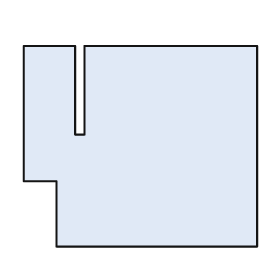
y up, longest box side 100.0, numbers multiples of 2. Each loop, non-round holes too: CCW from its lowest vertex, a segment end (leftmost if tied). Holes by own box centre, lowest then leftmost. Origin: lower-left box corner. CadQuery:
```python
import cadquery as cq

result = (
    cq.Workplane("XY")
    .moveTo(14.0, 0.0)
    .lineTo(100.0, 0.0)
    .lineTo(100.0, 86.0)
    .lineTo(26.0, 86.0)
    .lineTo(26.0, 48.0)
    .lineTo(22.0, 48.0)
    .lineTo(22.0, 86.0)
    .lineTo(0.0, 86.0)
    .lineTo(0.0, 28.0)
    .lineTo(14.0, 28.0)
    .close()
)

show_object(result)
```